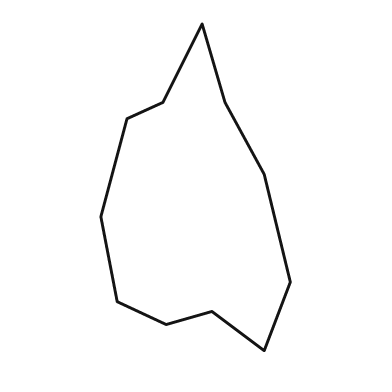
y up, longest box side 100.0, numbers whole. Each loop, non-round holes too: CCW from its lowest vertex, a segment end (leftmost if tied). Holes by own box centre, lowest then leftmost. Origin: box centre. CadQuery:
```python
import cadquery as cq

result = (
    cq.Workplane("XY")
    .moveTo(21.0, -50.0)
    .lineTo(29.0, -29.0)
    .lineTo(21.0, 4.0)
    .lineTo(9.0, 26.0)
    .lineTo(2.0, 50.0)
    .lineTo(-10.0, 26.0)
    .lineTo(-21.0, 21.0)
    .lineTo(-29.0, -9.0)
    .lineTo(-24.0, -35.0)
    .lineTo(-9.0, -42.0)
    .lineTo(5.0, -38.0)
    .close()
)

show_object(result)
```